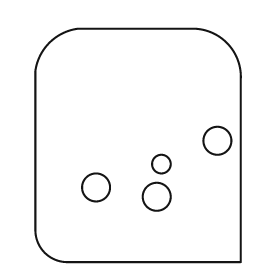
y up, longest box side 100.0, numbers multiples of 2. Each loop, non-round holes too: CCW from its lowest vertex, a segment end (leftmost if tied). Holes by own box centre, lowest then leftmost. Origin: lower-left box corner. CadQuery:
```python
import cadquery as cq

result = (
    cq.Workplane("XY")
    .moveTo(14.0, 0.0)
    .lineTo(88.0, 0.0)
    .lineTo(88.0, 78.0)
    .threePointArc((82.0, 94.0), (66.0, 100.0))
    .lineTo(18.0, 100.0)
    .threePointArc((6.0, 94.0), (0.0, 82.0))
    .lineTo(0.0, 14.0)
    .threePointArc((4.0, 4.0), (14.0, 0.0))
    .close()
    .moveTo(52.0, 28.0)
    .circle(6.0)
    .moveTo(26.0, 32.0)
    .circle(6.0)
    .moveTo(54.0, 42.0)
    .circle(4.0)
    .moveTo(78.0, 52.0)
    .circle(6.0)
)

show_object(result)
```